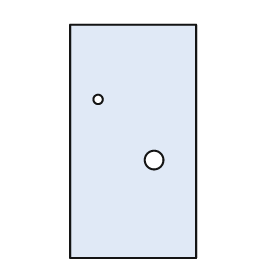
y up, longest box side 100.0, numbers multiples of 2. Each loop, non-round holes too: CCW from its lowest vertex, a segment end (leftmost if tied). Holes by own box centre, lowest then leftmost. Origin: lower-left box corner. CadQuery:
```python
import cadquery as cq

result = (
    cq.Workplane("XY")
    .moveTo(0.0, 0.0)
    .lineTo(54.0, 0.0)
    .lineTo(54.0, 100.0)
    .lineTo(0.0, 100.0)
    .close()
    .moveTo(36.0, 42.0)
    .circle(4.0)
    .moveTo(12.0, 68.0)
    .circle(2.0)
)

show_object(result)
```